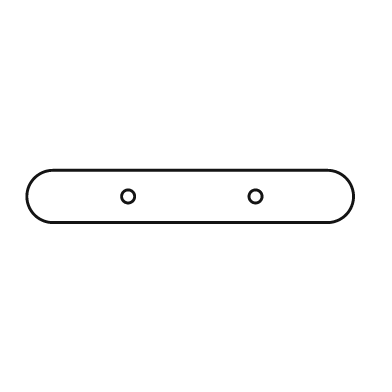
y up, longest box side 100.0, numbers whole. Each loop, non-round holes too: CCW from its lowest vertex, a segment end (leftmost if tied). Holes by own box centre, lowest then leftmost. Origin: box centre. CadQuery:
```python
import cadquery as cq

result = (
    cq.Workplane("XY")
    .moveTo(-42.0, -8.0)
    .lineTo(42.0, -8.0)
    .threePointArc((50.0, 0.0), (42.0, 8.0))
    .lineTo(-42.0, 8.0)
    .threePointArc((-50.0, 0.0), (-42.0, -8.0))
    .close()
    .moveTo(-19.0, 0.0)
    .circle(2.0)
    .moveTo(20.0, 0.0)
    .circle(2.0)
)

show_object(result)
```